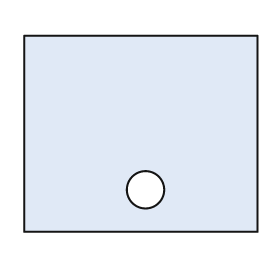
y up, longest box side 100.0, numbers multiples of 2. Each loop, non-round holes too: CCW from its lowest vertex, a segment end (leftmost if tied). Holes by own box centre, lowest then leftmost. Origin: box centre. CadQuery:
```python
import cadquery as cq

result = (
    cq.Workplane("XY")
    .moveTo(-50.0, -42.0)
    .lineTo(50.0, -42.0)
    .lineTo(50.0, 42.0)
    .lineTo(-50.0, 42.0)
    .close()
    .moveTo(2.0, -24.0)
    .circle(8.0)
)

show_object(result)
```